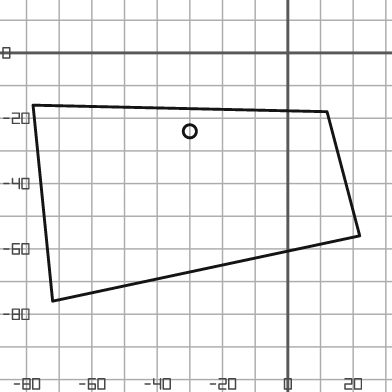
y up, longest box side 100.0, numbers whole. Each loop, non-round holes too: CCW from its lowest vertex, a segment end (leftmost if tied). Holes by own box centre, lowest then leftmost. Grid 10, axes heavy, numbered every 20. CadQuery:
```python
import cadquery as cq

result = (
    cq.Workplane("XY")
    .moveTo(-72.0, -76.0)
    .lineTo(22.0, -56.0)
    .lineTo(12.0, -18.0)
    .lineTo(-78.0, -16.0)
    .close()
    .moveTo(-30.0, -24.0)
    .circle(2.0)
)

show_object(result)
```